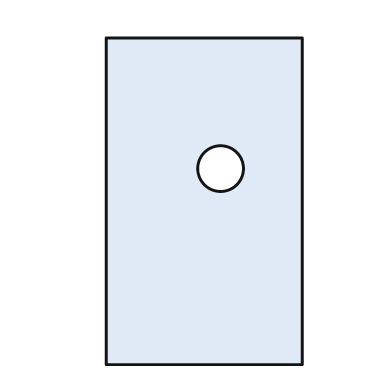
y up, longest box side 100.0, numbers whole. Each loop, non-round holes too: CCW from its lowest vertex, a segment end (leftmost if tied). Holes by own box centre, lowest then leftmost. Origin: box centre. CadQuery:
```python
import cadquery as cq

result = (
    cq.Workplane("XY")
    .moveTo(-30.0, -50.0)
    .lineTo(30.0, -50.0)
    .lineTo(30.0, 50.0)
    .lineTo(-30.0, 50.0)
    .close()
    .moveTo(5.0, 10.0)
    .circle(7.0)
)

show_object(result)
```